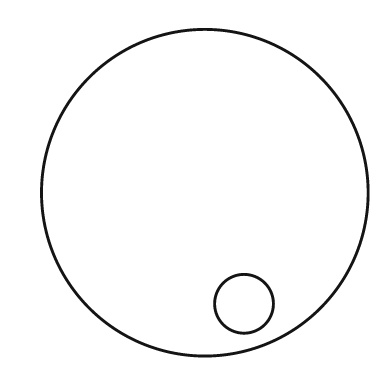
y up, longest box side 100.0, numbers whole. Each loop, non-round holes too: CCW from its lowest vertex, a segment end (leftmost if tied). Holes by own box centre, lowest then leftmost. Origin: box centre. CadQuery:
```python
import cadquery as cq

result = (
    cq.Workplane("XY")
    .moveTo(0.0, 0.0)
    .circle(50.0)
    .moveTo(12.0, -34.0)
    .circle(9.0)
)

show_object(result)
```